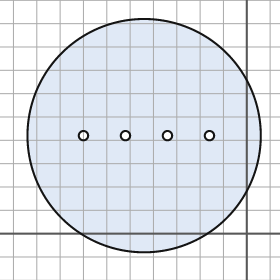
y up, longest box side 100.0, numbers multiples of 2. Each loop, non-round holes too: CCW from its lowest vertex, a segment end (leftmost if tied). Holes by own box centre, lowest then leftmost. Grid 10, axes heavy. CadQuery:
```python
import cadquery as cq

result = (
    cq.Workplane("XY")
    .moveTo(-44.0, 42.0)
    .circle(50.0)
    .moveTo(-70.0, 42.0)
    .circle(2.0)
    .moveTo(-52.0, 42.0)
    .circle(2.0)
    .moveTo(-34.0, 42.0)
    .circle(2.0)
    .moveTo(-16.0, 42.0)
    .circle(2.0)
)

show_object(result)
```